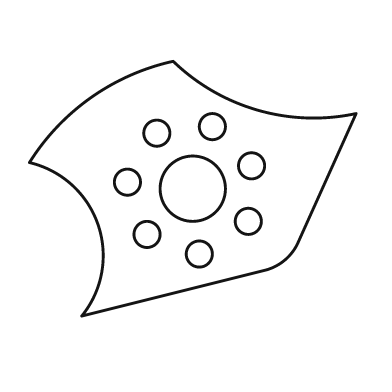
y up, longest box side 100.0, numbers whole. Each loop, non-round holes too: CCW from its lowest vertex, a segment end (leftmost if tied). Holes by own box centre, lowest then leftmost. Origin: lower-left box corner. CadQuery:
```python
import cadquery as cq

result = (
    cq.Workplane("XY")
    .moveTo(16.0, 0.0)
    .lineTo(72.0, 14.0)
    .threePointArc((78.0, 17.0), (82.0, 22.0))
    .lineTo(100.0, 62.0)
    .threePointArc((70.0, 63.0), (44.0, 78.0))
    .threePointArc((19.0, 67.0), (0.0, 47.0))
    .threePointArc((21.0, 28.0), (16.0, 0.0))
    .close()
    .moveTo(52.0, 19.0)
    .circle(4.0)
    .moveTo(36.0, 25.0)
    .circle(4.0)
    .moveTo(67.0, 29.0)
    .circle(4.0)
    .moveTo(50.0, 39.0)
    .circle(10.0)
    .moveTo(30.0, 41.0)
    .circle(4.0)
    .moveTo(68.0, 46.0)
    .circle(4.0)
    .moveTo(39.0, 56.0)
    .circle(4.0)
    .moveTo(56.0, 58.0)
    .circle(4.0)
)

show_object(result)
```